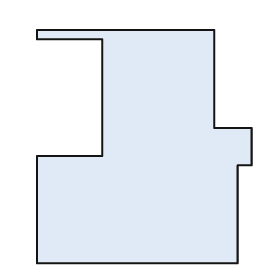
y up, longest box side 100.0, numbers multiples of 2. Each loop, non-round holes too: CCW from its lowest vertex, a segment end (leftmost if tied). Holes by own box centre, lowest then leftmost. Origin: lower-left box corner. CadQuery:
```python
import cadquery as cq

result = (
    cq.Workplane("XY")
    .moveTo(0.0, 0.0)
    .lineTo(86.0, 0.0)
    .lineTo(86.0, 42.0)
    .lineTo(92.0, 42.0)
    .lineTo(92.0, 58.0)
    .lineTo(76.0, 58.0)
    .lineTo(76.0, 100.0)
    .lineTo(0.0, 100.0)
    .lineTo(0.0, 96.0)
    .lineTo(28.0, 96.0)
    .lineTo(28.0, 46.0)
    .lineTo(0.0, 46.0)
    .close()
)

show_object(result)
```